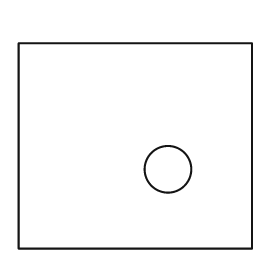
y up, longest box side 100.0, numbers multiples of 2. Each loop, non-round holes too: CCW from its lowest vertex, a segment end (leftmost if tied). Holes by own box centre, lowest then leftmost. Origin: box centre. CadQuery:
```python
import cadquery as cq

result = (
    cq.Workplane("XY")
    .moveTo(-50.0, -44.0)
    .lineTo(50.0, -44.0)
    .lineTo(50.0, 44.0)
    .lineTo(-50.0, 44.0)
    .close()
    .moveTo(14.0, -10.0)
    .circle(10.0)
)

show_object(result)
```